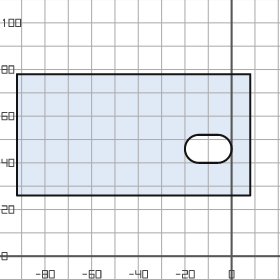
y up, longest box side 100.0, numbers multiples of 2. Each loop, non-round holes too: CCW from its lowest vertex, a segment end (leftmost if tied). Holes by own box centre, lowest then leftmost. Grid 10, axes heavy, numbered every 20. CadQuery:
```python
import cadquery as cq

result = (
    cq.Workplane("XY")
    .moveTo(-92.0, 26.0)
    .lineTo(8.0, 26.0)
    .lineTo(8.0, 78.0)
    .lineTo(-92.0, 78.0)
    .close()
    .moveTo(-14.0, 40.0)
    .lineTo(-6.0, 40.0)
    .threePointArc((0.0, 46.0), (-6.0, 52.0))
    .lineTo(-14.0, 52.0)
    .threePointArc((-20.0, 46.0), (-14.0, 40.0))
    .close()
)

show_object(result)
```